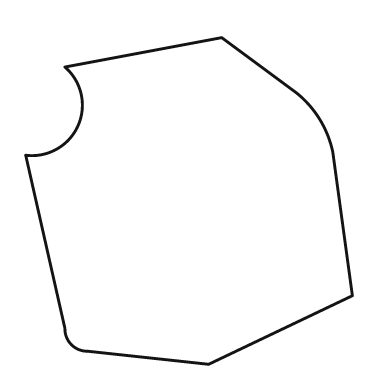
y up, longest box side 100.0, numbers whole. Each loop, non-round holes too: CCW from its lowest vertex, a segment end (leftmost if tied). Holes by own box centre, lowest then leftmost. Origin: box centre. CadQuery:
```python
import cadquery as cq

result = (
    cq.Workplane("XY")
    .moveTo(6.0, -50.0)
    .lineTo(50.0, -29.0)
    .lineTo(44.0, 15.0)
    .threePointArc((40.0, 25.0), (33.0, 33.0))
    .lineTo(10.0, 50.0)
    .lineTo(-38.0, 41.0)
    .threePointArc((-34.0, 23.0), (-50.0, 14.0))
    .lineTo(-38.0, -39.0)
    .threePointArc((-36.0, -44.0), (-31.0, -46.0))
    .close()
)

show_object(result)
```